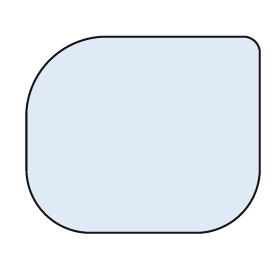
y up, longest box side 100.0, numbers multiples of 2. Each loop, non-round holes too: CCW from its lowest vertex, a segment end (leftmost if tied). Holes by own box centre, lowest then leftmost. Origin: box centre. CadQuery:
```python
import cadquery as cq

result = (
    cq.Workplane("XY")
    .moveTo(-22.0, -42.0)
    .lineTo(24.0, -42.0)
    .threePointArc((42.0, -34.0), (50.0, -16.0))
    .lineTo(50.0, 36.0)
    .threePointArc((48.0, 40.0), (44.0, 42.0))
    .lineTo(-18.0, 42.0)
    .threePointArc((-40.0, 32.0), (-50.0, 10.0))
    .lineTo(-50.0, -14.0)
    .threePointArc((-42.0, -34.0), (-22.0, -42.0))
    .close()
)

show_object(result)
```